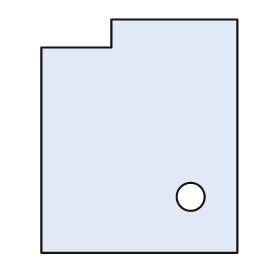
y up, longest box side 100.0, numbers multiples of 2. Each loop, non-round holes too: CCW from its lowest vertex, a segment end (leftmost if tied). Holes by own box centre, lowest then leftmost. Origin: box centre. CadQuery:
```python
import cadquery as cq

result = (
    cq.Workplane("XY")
    .moveTo(-42.0, -50.0)
    .lineTo(42.0, -50.0)
    .lineTo(42.0, 50.0)
    .lineTo(-12.0, 50.0)
    .lineTo(-12.0, 38.0)
    .lineTo(-42.0, 38.0)
    .close()
    .moveTo(22.0, -26.0)
    .circle(6.0)
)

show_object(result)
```